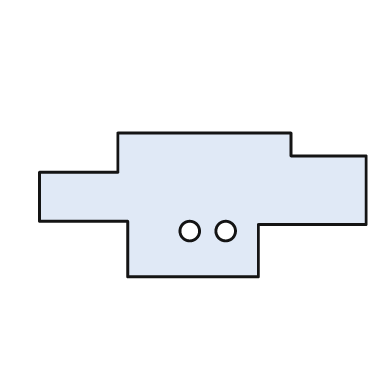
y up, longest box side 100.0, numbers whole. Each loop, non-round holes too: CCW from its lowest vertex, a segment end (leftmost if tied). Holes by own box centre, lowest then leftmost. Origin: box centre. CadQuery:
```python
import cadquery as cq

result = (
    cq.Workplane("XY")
    .moveTo(-23.0, -22.0)
    .lineTo(17.0, -22.0)
    .lineTo(17.0, -6.0)
    .lineTo(50.0, -6.0)
    .lineTo(50.0, 15.0)
    .lineTo(27.0, 15.0)
    .lineTo(27.0, 22.0)
    .lineTo(-26.0, 22.0)
    .lineTo(-26.0, 10.0)
    .lineTo(-50.0, 10.0)
    .lineTo(-50.0, -5.0)
    .lineTo(-23.0, -5.0)
    .close()
    .moveTo(-4.0, -8.0)
    .circle(3.0)
    .moveTo(7.0, -8.0)
    .circle(3.0)
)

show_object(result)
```